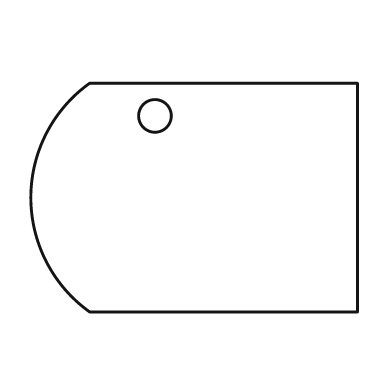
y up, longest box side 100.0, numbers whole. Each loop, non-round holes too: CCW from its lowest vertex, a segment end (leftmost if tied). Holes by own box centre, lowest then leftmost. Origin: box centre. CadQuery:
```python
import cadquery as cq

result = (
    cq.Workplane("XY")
    .moveTo(-32.0, -35.0)
    .lineTo(50.0, -35.0)
    .lineTo(50.0, 35.0)
    .lineTo(-32.0, 35.0)
    .threePointArc((-50.0, 0.0), (-32.0, -35.0))
    .close()
    .moveTo(-12.0, 25.0)
    .circle(5.0)
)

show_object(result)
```